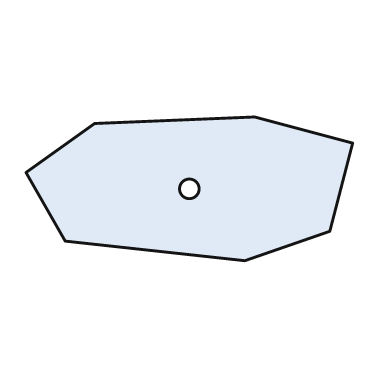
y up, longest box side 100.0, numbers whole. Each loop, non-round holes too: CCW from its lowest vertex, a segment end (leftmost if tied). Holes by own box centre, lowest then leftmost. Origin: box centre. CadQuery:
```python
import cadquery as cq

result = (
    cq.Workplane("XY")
    .moveTo(17.0, -22.0)
    .lineTo(43.0, -13.0)
    .lineTo(50.0, 14.0)
    .lineTo(20.0, 22.0)
    .lineTo(-29.0, 20.0)
    .lineTo(-50.0, 5.0)
    .lineTo(-38.0, -16.0)
    .close()
    .moveTo(0.0, 0.0)
    .circle(3.0)
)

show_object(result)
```